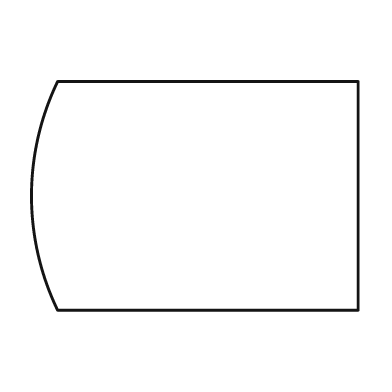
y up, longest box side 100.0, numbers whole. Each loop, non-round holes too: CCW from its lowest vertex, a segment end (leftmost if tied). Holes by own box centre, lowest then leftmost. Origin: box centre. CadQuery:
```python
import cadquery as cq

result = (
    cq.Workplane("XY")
    .moveTo(-42.0, -35.0)
    .lineTo(50.0, -35.0)
    .lineTo(50.0, 35.0)
    .lineTo(-42.0, 35.0)
    .threePointArc((-50.0, 0.0), (-42.0, -35.0))
    .close()
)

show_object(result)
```